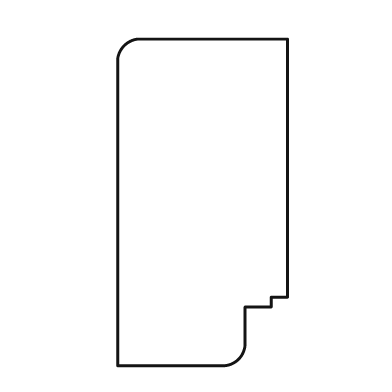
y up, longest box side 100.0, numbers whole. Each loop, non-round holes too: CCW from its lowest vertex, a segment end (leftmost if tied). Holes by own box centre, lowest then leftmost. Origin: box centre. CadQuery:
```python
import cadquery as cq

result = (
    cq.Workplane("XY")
    .moveTo(-26.0, -50.0)
    .lineTo(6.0, -50.0)
    .threePointArc((11.0, -48.0), (13.0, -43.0))
    .lineTo(13.0, -32.0)
    .lineTo(21.0, -32.0)
    .lineTo(21.0, -29.0)
    .lineTo(26.0, -29.0)
    .lineTo(26.0, 50.0)
    .lineTo(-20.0, 50.0)
    .threePointArc((-24.0, 48.0), (-26.0, 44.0))
    .close()
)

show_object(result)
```